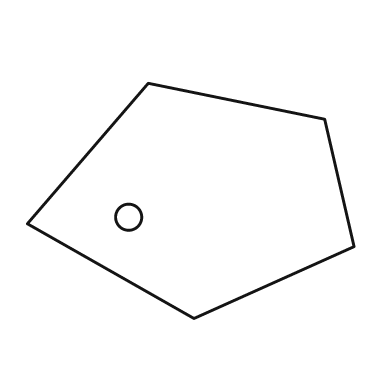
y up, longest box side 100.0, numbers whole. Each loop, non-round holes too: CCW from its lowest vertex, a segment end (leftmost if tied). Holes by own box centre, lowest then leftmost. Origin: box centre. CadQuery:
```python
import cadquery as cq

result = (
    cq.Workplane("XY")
    .moveTo(1.0, -36.0)
    .lineTo(50.0, -14.0)
    .lineTo(41.0, 25.0)
    .lineTo(-13.0, 36.0)
    .lineTo(-50.0, -7.0)
    .close()
    .moveTo(-19.0, -5.0)
    .circle(4.0)
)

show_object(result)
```